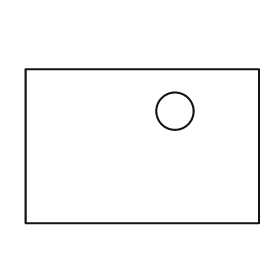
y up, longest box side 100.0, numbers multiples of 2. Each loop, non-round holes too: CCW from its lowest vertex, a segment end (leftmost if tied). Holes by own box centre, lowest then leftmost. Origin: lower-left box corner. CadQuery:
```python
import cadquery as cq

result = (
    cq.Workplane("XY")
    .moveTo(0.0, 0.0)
    .lineTo(100.0, 0.0)
    .lineTo(100.0, 66.0)
    .lineTo(0.0, 66.0)
    .close()
    .moveTo(64.0, 48.0)
    .circle(8.0)
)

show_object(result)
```